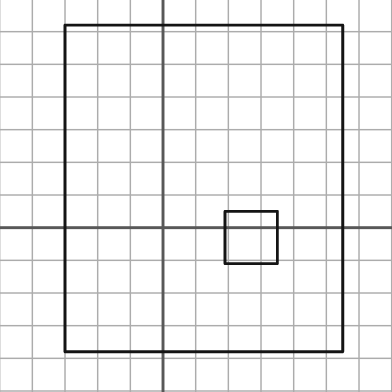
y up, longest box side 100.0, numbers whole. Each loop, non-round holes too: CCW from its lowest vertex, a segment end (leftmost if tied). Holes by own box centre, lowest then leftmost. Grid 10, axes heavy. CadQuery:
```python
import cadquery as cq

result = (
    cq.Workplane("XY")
    .moveTo(-30.0, -38.0)
    .lineTo(55.0, -38.0)
    .lineTo(55.0, 62.0)
    .lineTo(-30.0, 62.0)
    .close()
    .moveTo(19.0, -11.0)
    .lineTo(35.0, -11.0)
    .lineTo(35.0, 5.0)
    .lineTo(19.0, 5.0)
    .close()
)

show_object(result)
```